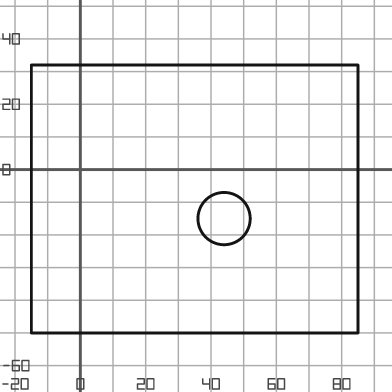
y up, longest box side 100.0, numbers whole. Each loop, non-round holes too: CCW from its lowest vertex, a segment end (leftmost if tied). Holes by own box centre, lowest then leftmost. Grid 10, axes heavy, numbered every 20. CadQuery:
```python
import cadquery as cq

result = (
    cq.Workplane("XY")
    .moveTo(-15.0, -50.0)
    .lineTo(85.0, -50.0)
    .lineTo(85.0, 32.0)
    .lineTo(-15.0, 32.0)
    .close()
    .moveTo(44.0, -15.0)
    .circle(8.0)
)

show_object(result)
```